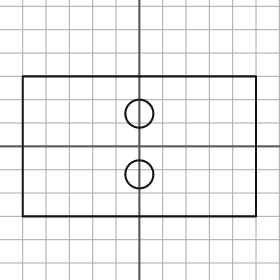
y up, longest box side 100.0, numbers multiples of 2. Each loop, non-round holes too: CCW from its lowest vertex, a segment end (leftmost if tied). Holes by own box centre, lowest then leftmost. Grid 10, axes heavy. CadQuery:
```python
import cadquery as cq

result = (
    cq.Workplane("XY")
    .moveTo(-50.0, -30.0)
    .lineTo(50.0, -30.0)
    .lineTo(50.0, 30.0)
    .lineTo(-50.0, 30.0)
    .close()
    .moveTo(0.0, -12.0)
    .circle(6.0)
    .moveTo(0.0, 14.0)
    .circle(6.0)
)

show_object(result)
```